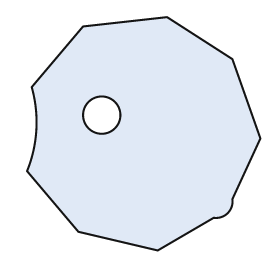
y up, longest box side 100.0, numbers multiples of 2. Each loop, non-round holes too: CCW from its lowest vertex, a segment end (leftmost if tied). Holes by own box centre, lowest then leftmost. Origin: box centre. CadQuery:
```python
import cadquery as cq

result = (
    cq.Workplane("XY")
    .moveTo(6.0, -50.0)
    .lineTo(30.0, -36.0)
    .threePointArc((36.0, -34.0), (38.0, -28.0))
    .lineTo(50.0, -2.0)
    .lineTo(38.0, 32.0)
    .lineTo(10.0, 50.0)
    .lineTo(-26.0, 46.0)
    .lineTo(-48.0, 20.0)
    .threePointArc((-46.0, 2.0), (-50.0, -16.0))
    .lineTo(-28.0, -42.0)
    .close()
    .moveTo(-18.0, 8.0)
    .circle(8.0)
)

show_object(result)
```